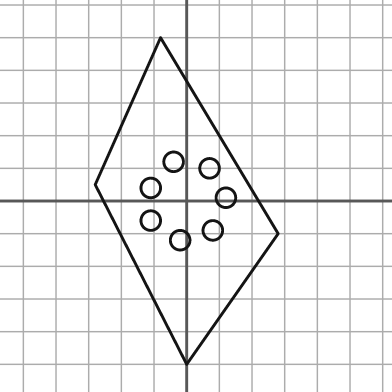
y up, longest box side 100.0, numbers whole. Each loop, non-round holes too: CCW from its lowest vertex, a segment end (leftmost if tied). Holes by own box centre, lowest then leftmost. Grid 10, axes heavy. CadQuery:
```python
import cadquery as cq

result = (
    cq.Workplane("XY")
    .moveTo(0.0, -50.0)
    .lineTo(28.0, -10.0)
    .lineTo(-8.0, 50.0)
    .lineTo(-28.0, 5.0)
    .close()
    .moveTo(-2.0, -12.0)
    .circle(3.0)
    .moveTo(8.0, -9.0)
    .circle(3.0)
    .moveTo(-11.0, -6.0)
    .circle(3.0)
    .moveTo(12.0, 1.0)
    .circle(3.0)
    .moveTo(-11.0, 4.0)
    .circle(3.0)
    .moveTo(7.0, 10.0)
    .circle(3.0)
    .moveTo(-4.0, 12.0)
    .circle(3.0)
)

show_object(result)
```